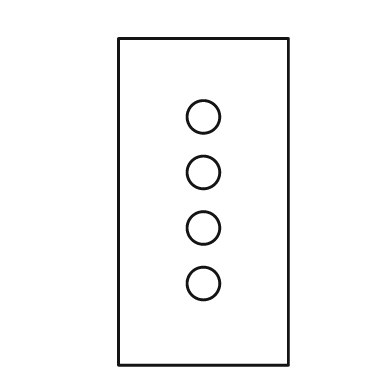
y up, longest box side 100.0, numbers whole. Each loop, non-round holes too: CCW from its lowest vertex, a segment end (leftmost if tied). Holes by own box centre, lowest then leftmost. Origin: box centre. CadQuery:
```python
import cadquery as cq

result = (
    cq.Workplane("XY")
    .moveTo(-26.0, -50.0)
    .lineTo(26.0, -50.0)
    .lineTo(26.0, 50.0)
    .lineTo(-26.0, 50.0)
    .close()
    .moveTo(0.0, -25.0)
    .circle(5.0)
    .moveTo(0.0, -8.0)
    .circle(5.0)
    .moveTo(0.0, 9.0)
    .circle(5.0)
    .moveTo(0.0, 26.0)
    .circle(5.0)
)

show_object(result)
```